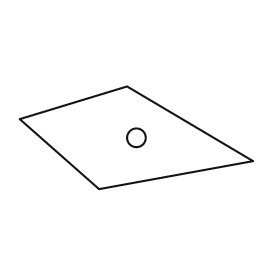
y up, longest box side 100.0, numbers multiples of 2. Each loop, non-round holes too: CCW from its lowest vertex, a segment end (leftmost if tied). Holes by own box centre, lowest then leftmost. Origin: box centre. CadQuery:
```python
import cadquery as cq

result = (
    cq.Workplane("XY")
    .moveTo(-16.0, -22.0)
    .lineTo(50.0, -10.0)
    .lineTo(-4.0, 22.0)
    .lineTo(-50.0, 8.0)
    .close()
    .moveTo(0.0, 0.0)
    .circle(4.0)
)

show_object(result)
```